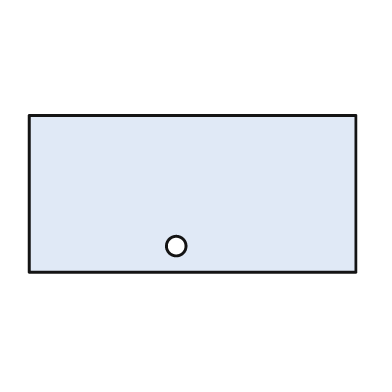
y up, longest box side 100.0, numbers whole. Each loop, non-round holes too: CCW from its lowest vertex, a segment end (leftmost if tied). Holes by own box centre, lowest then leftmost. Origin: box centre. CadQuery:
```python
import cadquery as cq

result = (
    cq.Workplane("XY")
    .moveTo(-50.0, -24.0)
    .lineTo(50.0, -24.0)
    .lineTo(50.0, 24.0)
    .lineTo(-50.0, 24.0)
    .close()
    .moveTo(-5.0, -16.0)
    .circle(3.0)
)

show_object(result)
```